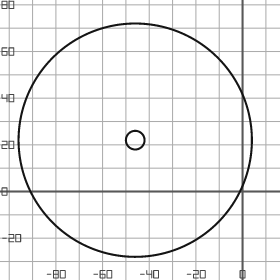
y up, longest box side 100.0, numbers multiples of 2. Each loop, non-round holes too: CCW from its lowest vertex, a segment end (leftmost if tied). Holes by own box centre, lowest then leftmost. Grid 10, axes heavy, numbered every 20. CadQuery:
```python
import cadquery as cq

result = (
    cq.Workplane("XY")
    .moveTo(-46.0, 22.0)
    .circle(50.0)
    .moveTo(-46.0, 22.0)
    .circle(4.0)
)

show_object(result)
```